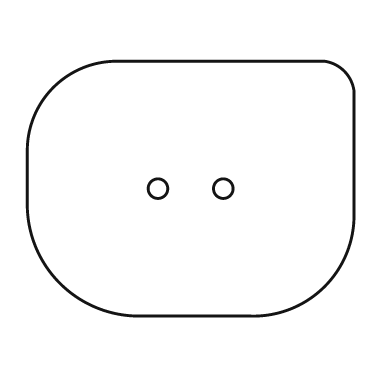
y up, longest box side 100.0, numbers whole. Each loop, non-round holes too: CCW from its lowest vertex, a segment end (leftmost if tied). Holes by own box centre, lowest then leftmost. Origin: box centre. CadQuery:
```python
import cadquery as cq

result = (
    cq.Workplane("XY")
    .moveTo(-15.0, -39.0)
    .lineTo(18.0, -39.0)
    .threePointArc((41.0, -30.0), (50.0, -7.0))
    .lineTo(50.0, 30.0)
    .threePointArc((47.0, 36.0), (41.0, 39.0))
    .lineTo(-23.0, 39.0)
    .threePointArc((-42.0, 31.0), (-50.0, 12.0))
    .lineTo(-50.0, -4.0)
    .threePointArc((-40.0, -29.0), (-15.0, -39.0))
    .close()
    .moveTo(-10.0, 0.0)
    .circle(3.0)
    .moveTo(10.0, 0.0)
    .circle(3.0)
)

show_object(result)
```